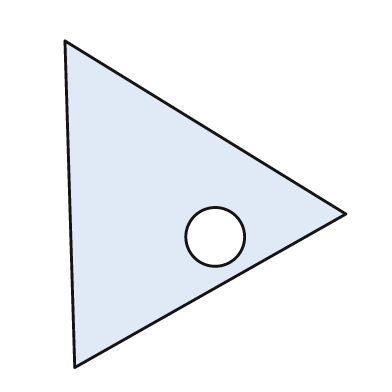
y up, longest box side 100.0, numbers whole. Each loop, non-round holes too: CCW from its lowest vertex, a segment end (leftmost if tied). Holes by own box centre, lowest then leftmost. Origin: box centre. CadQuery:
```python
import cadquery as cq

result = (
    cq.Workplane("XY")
    .moveTo(-40.0, -50.0)
    .lineTo(43.0, -3.0)
    .lineTo(-43.0, 50.0)
    .close()
    .moveTo(3.0, -10.0)
    .circle(9.0)
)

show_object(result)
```